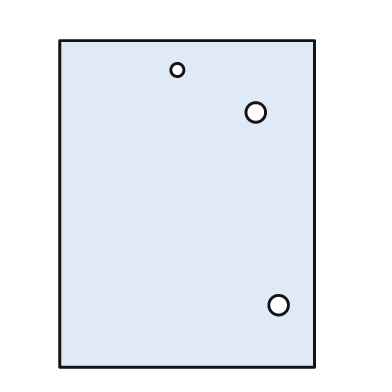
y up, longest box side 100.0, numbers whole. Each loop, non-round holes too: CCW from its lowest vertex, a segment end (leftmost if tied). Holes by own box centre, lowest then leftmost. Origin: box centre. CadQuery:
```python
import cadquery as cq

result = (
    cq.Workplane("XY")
    .moveTo(-39.0, -50.0)
    .lineTo(39.0, -50.0)
    .lineTo(39.0, 50.0)
    .lineTo(-39.0, 50.0)
    .close()
    .moveTo(28.0, -31.0)
    .circle(3.0)
    .moveTo(21.0, 28.0)
    .circle(3.0)
    .moveTo(-3.0, 41.0)
    .circle(2.0)
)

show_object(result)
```